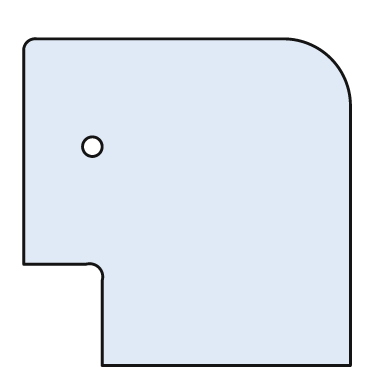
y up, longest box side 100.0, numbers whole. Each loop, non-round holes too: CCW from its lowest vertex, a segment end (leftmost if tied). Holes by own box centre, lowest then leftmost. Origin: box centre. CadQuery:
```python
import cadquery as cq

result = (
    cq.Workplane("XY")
    .moveTo(-26.0, -50.0)
    .lineTo(50.0, -50.0)
    .lineTo(50.0, 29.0)
    .threePointArc((44.0, 44.0), (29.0, 50.0))
    .lineTo(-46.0, 50.0)
    .threePointArc((-49.0, 49.0), (-50.0, 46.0))
    .lineTo(-50.0, -19.0)
    .lineTo(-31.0, -19.0)
    .threePointArc((-27.0, -20.0), (-26.0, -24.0))
    .close()
    .moveTo(-29.0, 17.0)
    .circle(3.0)
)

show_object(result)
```